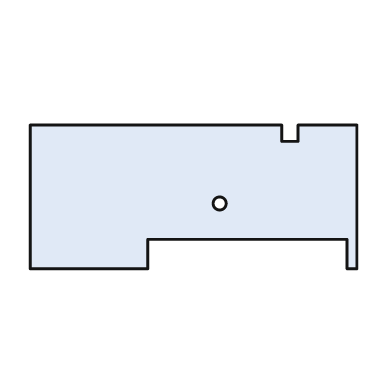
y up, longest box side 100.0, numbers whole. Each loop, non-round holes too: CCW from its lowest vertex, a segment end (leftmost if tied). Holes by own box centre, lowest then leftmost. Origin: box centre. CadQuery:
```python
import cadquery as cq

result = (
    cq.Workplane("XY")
    .moveTo(-50.0, -22.0)
    .lineTo(-14.0, -22.0)
    .lineTo(-14.0, -13.0)
    .lineTo(47.0, -13.0)
    .lineTo(47.0, -22.0)
    .lineTo(50.0, -22.0)
    .lineTo(50.0, 22.0)
    .lineTo(32.0, 22.0)
    .lineTo(32.0, 17.0)
    .lineTo(27.0, 17.0)
    .lineTo(27.0, 22.0)
    .lineTo(-50.0, 22.0)
    .close()
    .moveTo(8.0, -2.0)
    .circle(2.0)
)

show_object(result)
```